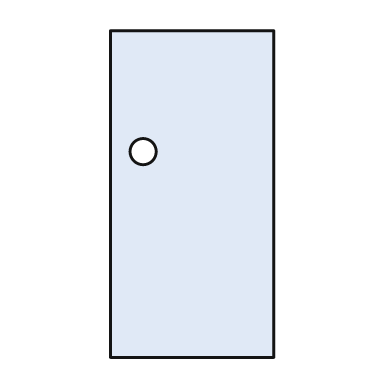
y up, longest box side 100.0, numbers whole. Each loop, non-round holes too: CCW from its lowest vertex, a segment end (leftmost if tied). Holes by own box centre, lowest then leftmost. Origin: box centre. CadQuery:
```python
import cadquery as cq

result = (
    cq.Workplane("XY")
    .moveTo(-25.0, -50.0)
    .lineTo(25.0, -50.0)
    .lineTo(25.0, 50.0)
    .lineTo(-25.0, 50.0)
    .close()
    .moveTo(-15.0, 13.0)
    .circle(4.0)
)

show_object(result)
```